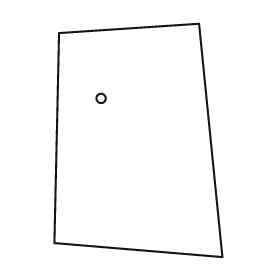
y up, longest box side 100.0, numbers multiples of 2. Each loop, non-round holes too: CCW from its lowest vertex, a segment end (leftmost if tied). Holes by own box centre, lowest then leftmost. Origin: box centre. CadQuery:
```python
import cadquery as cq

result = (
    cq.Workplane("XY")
    .moveTo(36.0, -50.0)
    .lineTo(26.0, 50.0)
    .lineTo(-34.0, 46.0)
    .lineTo(-36.0, -44.0)
    .close()
    .moveTo(-16.0, 18.0)
    .circle(2.0)
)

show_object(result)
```